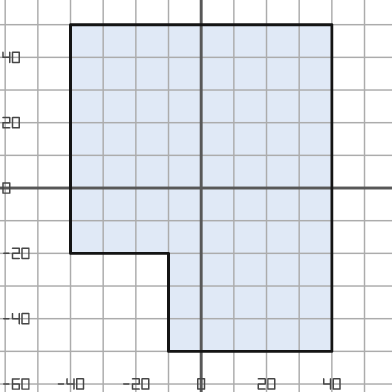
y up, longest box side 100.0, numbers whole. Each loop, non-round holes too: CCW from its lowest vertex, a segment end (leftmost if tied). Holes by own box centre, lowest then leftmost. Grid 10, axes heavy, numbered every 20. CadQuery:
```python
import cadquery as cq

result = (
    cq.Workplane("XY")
    .moveTo(-10.0, -50.0)
    .lineTo(40.0, -50.0)
    .lineTo(40.0, 50.0)
    .lineTo(-40.0, 50.0)
    .lineTo(-40.0, -20.0)
    .lineTo(-10.0, -20.0)
    .close()
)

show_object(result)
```